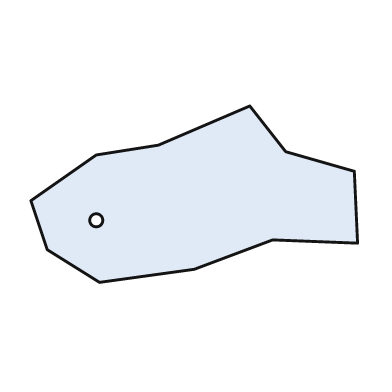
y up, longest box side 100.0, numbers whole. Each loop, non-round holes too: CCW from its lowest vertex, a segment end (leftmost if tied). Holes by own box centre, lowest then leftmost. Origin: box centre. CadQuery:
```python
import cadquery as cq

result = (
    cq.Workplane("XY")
    .moveTo(-29.0, -27.0)
    .lineTo(0.0, -23.0)
    .lineTo(24.0, -14.0)
    .lineTo(50.0, -15.0)
    .lineTo(49.0, 7.0)
    .lineTo(28.0, 13.0)
    .lineTo(17.0, 27.0)
    .lineTo(-11.0, 15.0)
    .lineTo(-30.0, 12.0)
    .lineTo(-50.0, -2.0)
    .lineTo(-45.0, -17.0)
    .close()
    .moveTo(-30.0, -8.0)
    .circle(2.0)
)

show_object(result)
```